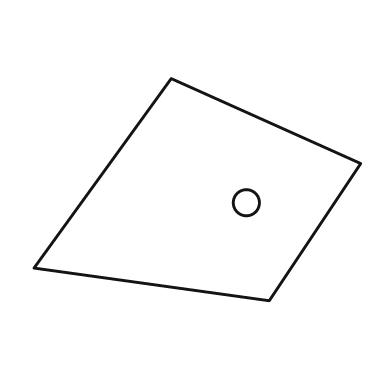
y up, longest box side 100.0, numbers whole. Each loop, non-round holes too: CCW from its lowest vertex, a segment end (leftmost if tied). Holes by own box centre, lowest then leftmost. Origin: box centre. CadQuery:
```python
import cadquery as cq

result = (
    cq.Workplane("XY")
    .moveTo(22.0, -34.0)
    .lineTo(50.0, 8.0)
    .lineTo(-8.0, 34.0)
    .lineTo(-50.0, -24.0)
    .close()
    .moveTo(15.0, -4.0)
    .circle(4.0)
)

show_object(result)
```